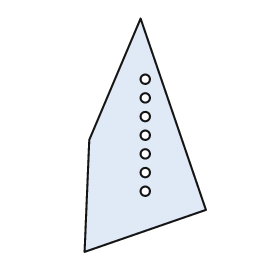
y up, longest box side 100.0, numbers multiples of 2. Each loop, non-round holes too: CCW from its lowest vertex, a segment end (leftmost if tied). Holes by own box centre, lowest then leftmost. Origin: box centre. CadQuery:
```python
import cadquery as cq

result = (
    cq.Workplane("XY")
    .moveTo(-26.0, -50.0)
    .lineTo(26.0, -32.0)
    .lineTo(-2.0, 50.0)
    .lineTo(-24.0, -2.0)
    .close()
    .moveTo(0.0, -24.0)
    .circle(2.0)
    .moveTo(0.0, -16.0)
    .circle(2.0)
    .moveTo(0.0, -8.0)
    .circle(2.0)
    .moveTo(0.0, 0.0)
    .circle(2.0)
    .moveTo(0.0, 8.0)
    .circle(2.0)
    .moveTo(0.0, 16.0)
    .circle(2.0)
    .moveTo(0.0, 24.0)
    .circle(2.0)
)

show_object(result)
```